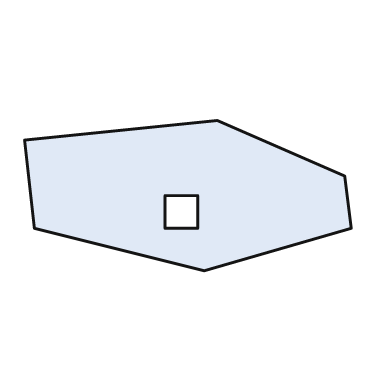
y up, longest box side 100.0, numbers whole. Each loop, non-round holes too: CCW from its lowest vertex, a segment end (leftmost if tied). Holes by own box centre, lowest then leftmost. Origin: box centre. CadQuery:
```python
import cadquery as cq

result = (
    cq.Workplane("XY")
    .moveTo(5.0, -23.0)
    .lineTo(50.0, -10.0)
    .lineTo(48.0, 6.0)
    .lineTo(9.0, 23.0)
    .lineTo(-50.0, 17.0)
    .lineTo(-47.0, -10.0)
    .close()
    .moveTo(-7.0, -10.0)
    .lineTo(3.0, -10.0)
    .lineTo(3.0, 0.0)
    .lineTo(-7.0, 0.0)
    .close()
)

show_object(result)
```